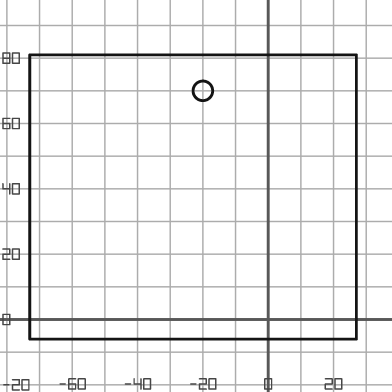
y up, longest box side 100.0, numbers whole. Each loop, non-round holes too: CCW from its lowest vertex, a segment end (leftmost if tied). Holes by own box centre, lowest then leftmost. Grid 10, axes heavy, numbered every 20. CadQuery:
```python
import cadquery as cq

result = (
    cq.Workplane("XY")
    .moveTo(-73.0, -6.0)
    .lineTo(27.0, -6.0)
    .lineTo(27.0, 81.0)
    .lineTo(-73.0, 81.0)
    .close()
    .moveTo(-20.0, 70.0)
    .circle(3.0)
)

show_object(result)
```